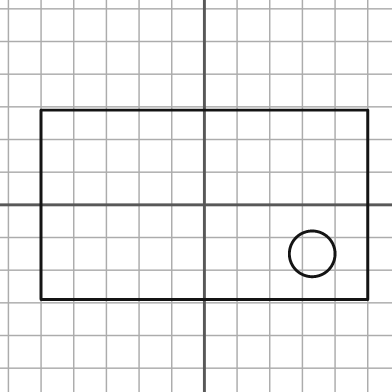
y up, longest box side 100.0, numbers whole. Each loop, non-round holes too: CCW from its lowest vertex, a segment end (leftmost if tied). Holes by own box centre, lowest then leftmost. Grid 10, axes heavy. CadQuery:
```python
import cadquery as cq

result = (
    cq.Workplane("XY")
    .moveTo(-50.0, -29.0)
    .lineTo(50.0, -29.0)
    .lineTo(50.0, 29.0)
    .lineTo(-50.0, 29.0)
    .close()
    .moveTo(33.0, -15.0)
    .circle(7.0)
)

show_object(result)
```